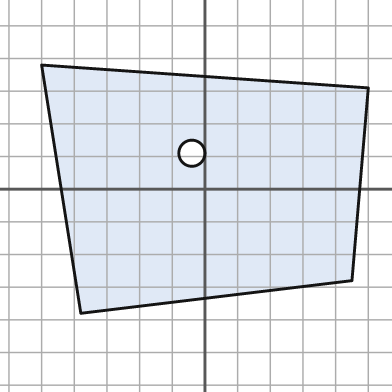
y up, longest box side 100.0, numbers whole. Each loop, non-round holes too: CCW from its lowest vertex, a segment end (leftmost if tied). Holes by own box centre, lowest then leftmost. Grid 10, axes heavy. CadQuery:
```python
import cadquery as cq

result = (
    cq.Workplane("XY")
    .moveTo(-38.0, -38.0)
    .lineTo(45.0, -28.0)
    .lineTo(50.0, 31.0)
    .lineTo(-50.0, 38.0)
    .close()
    .moveTo(-4.0, 11.0)
    .circle(4.0)
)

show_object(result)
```